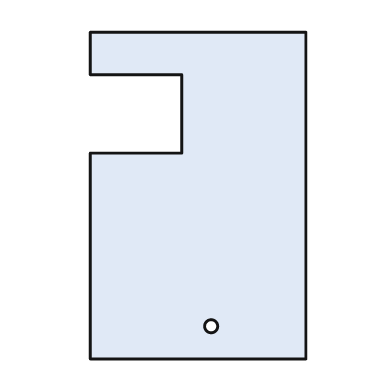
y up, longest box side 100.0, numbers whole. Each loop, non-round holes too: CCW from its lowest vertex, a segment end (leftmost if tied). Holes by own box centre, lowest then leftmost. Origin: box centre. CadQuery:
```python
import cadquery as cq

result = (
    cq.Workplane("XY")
    .moveTo(-33.0, -50.0)
    .lineTo(33.0, -50.0)
    .lineTo(33.0, 50.0)
    .lineTo(-33.0, 50.0)
    .lineTo(-33.0, 37.0)
    .lineTo(-5.0, 37.0)
    .lineTo(-5.0, 13.0)
    .lineTo(-33.0, 13.0)
    .close()
    .moveTo(4.0, -40.0)
    .circle(2.0)
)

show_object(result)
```